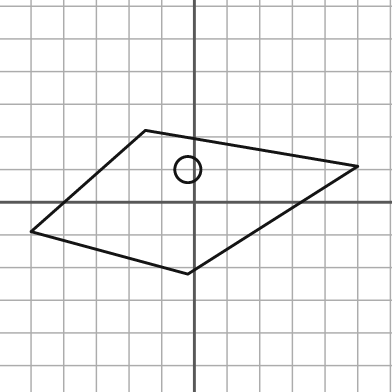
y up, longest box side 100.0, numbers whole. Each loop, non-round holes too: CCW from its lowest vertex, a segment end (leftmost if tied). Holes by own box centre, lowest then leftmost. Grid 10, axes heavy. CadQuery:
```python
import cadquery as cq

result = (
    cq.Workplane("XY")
    .moveTo(-2.0, -22.0)
    .lineTo(50.0, 11.0)
    .lineTo(-15.0, 22.0)
    .lineTo(-50.0, -9.0)
    .close()
    .moveTo(-2.0, 10.0)
    .circle(4.0)
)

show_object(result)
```